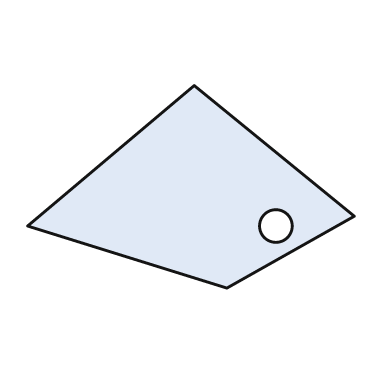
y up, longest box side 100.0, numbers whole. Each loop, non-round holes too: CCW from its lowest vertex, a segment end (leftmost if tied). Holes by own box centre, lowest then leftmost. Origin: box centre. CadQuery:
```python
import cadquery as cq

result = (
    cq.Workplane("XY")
    .moveTo(11.0, -31.0)
    .lineTo(50.0, -9.0)
    .lineTo(1.0, 31.0)
    .lineTo(-50.0, -12.0)
    .close()
    .moveTo(26.0, -12.0)
    .circle(5.0)
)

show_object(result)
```